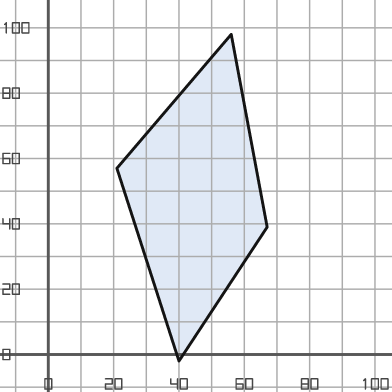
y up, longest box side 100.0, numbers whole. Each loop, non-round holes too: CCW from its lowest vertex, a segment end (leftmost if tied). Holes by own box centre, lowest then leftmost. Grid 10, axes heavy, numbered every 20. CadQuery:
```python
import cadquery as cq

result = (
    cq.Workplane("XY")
    .moveTo(40.0, -2.0)
    .lineTo(67.0, 39.0)
    .lineTo(56.0, 98.0)
    .lineTo(21.0, 57.0)
    .close()
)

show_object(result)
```